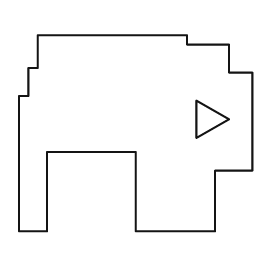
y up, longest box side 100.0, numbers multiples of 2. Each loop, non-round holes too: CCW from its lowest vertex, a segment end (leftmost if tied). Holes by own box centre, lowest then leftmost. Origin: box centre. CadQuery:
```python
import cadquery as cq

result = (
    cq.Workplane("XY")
    .moveTo(-50.0, -42.0)
    .lineTo(-38.0, -42.0)
    .lineTo(-38.0, -8.0)
    .lineTo(0.0, -8.0)
    .lineTo(0.0, -42.0)
    .lineTo(34.0, -42.0)
    .lineTo(34.0, -16.0)
    .lineTo(50.0, -16.0)
    .lineTo(50.0, 26.0)
    .lineTo(40.0, 26.0)
    .lineTo(40.0, 38.0)
    .lineTo(22.0, 38.0)
    .lineTo(22.0, 42.0)
    .lineTo(-42.0, 42.0)
    .lineTo(-42.0, 28.0)
    .lineTo(-46.0, 28.0)
    .lineTo(-46.0, 16.0)
    .lineTo(-50.0, 16.0)
    .close()
    .moveTo(26.0, -2.0)
    .lineTo(40.0, 6.0)
    .lineTo(26.0, 14.0)
    .close()
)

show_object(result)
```